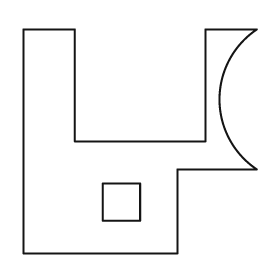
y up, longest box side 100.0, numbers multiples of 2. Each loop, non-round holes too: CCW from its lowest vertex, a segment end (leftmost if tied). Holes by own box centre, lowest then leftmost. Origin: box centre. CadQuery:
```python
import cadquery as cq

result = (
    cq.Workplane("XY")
    .moveTo(-50.0, -48.0)
    .lineTo(16.0, -48.0)
    .lineTo(16.0, -12.0)
    .lineTo(50.0, -12.0)
    .threePointArc((34.0, 18.0), (50.0, 48.0))
    .lineTo(28.0, 48.0)
    .lineTo(28.0, 0.0)
    .lineTo(-28.0, 0.0)
    .lineTo(-28.0, 48.0)
    .lineTo(-50.0, 48.0)
    .close()
    .moveTo(-16.0, -34.0)
    .lineTo(0.0, -34.0)
    .lineTo(0.0, -18.0)
    .lineTo(-16.0, -18.0)
    .close()
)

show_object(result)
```